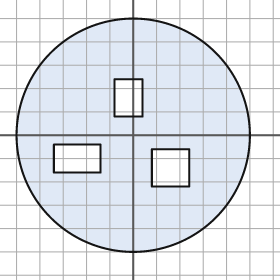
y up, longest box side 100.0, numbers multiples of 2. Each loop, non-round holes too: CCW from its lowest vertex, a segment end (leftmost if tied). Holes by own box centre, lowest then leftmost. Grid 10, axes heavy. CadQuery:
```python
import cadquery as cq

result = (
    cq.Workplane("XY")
    .moveTo(0.0, 0.0)
    .circle(50.0)
    .moveTo(8.0, -22.0)
    .lineTo(24.0, -22.0)
    .lineTo(24.0, -6.0)
    .lineTo(8.0, -6.0)
    .close()
    .moveTo(-34.0, -16.0)
    .lineTo(-14.0, -16.0)
    .lineTo(-14.0, -4.0)
    .lineTo(-34.0, -4.0)
    .close()
    .moveTo(-8.0, 8.0)
    .lineTo(4.0, 8.0)
    .lineTo(4.0, 24.0)
    .lineTo(-8.0, 24.0)
    .close()
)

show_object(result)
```